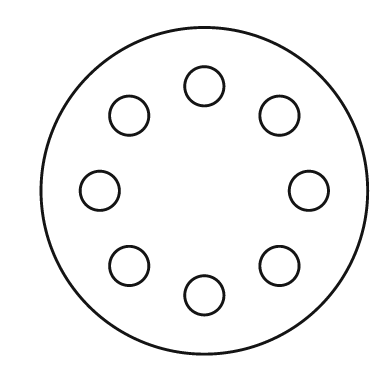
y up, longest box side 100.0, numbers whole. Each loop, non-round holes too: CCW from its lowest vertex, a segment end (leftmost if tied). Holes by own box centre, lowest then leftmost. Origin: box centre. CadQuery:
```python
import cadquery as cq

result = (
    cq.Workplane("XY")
    .moveTo(0.0, 0.0)
    .circle(50.0)
    .moveTo(0.0, -32.0)
    .circle(6.0)
    .moveTo(-23.0, -23.0)
    .circle(6.0)
    .moveTo(23.0, -23.0)
    .circle(6.0)
    .moveTo(-32.0, 0.0)
    .circle(6.0)
    .moveTo(32.0, 0.0)
    .circle(6.0)
    .moveTo(-23.0, 23.0)
    .circle(6.0)
    .moveTo(23.0, 23.0)
    .circle(6.0)
    .moveTo(0.0, 32.0)
    .circle(6.0)
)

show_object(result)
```